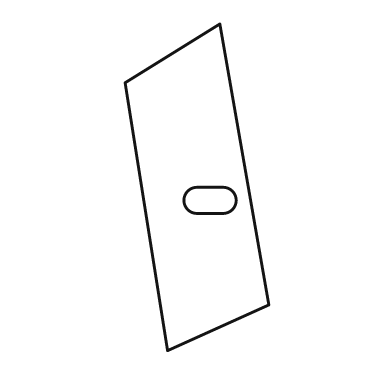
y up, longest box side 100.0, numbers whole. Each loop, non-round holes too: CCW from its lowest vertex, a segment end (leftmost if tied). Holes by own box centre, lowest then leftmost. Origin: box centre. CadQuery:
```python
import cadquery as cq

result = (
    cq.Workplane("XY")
    .moveTo(-9.0, -50.0)
    .lineTo(22.0, -36.0)
    .lineTo(7.0, 50.0)
    .lineTo(-22.0, 32.0)
    .close()
    .moveTo(0.0, -8.0)
    .lineTo(8.0, -8.0)
    .threePointArc((12.0, -4.0), (8.0, 0.0))
    .lineTo(0.0, 0.0)
    .threePointArc((-4.0, -4.0), (0.0, -8.0))
    .close()
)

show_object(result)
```